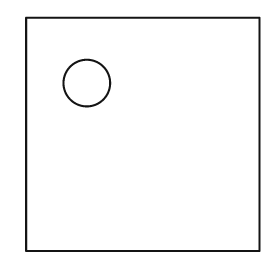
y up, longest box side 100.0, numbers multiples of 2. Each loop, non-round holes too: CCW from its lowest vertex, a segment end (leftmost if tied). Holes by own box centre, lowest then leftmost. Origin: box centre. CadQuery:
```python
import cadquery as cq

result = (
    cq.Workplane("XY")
    .moveTo(-50.0, -50.0)
    .lineTo(50.0, -50.0)
    .lineTo(50.0, 50.0)
    .lineTo(-50.0, 50.0)
    .close()
    .moveTo(-24.0, 22.0)
    .circle(10.0)
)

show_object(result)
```